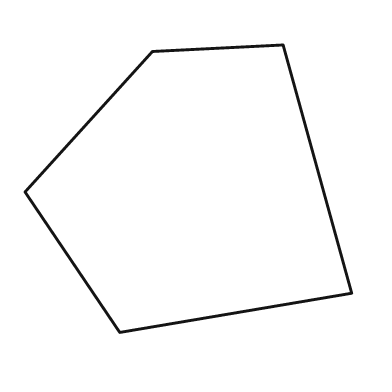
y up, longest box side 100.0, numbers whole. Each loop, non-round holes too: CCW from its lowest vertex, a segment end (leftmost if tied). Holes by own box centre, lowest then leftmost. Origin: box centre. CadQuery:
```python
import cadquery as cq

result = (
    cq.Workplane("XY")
    .moveTo(-21.0, -44.0)
    .lineTo(50.0, -32.0)
    .lineTo(29.0, 44.0)
    .lineTo(-11.0, 42.0)
    .lineTo(-50.0, -1.0)
    .close()
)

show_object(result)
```